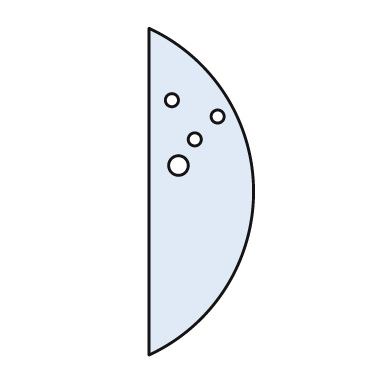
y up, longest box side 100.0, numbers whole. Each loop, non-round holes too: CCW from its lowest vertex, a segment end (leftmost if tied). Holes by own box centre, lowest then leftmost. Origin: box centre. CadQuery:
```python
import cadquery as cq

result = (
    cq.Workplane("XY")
    .moveTo(-16.0, -50.0)
    .threePointArc((16.0, 0.0), (-16.0, 50.0))
    .close()
    .moveTo(-7.0, 8.0)
    .circle(3.0)
    .moveTo(-2.0, 16.0)
    .circle(2.0)
    .moveTo(5.0, 23.0)
    .circle(2.0)
    .moveTo(-9.0, 28.0)
    .circle(2.0)
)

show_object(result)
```